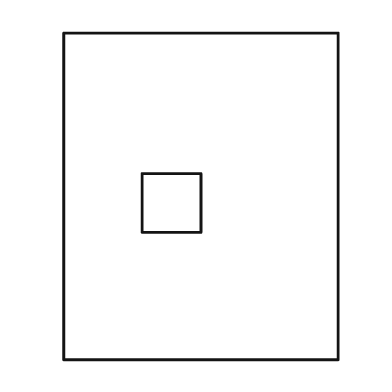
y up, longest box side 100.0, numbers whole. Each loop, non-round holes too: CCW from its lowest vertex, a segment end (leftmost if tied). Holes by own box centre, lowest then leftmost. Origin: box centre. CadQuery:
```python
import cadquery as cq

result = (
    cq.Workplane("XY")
    .moveTo(-42.0, -50.0)
    .lineTo(42.0, -50.0)
    .lineTo(42.0, 50.0)
    .lineTo(-42.0, 50.0)
    .close()
    .moveTo(-18.0, -11.0)
    .lineTo(0.0, -11.0)
    .lineTo(0.0, 7.0)
    .lineTo(-18.0, 7.0)
    .close()
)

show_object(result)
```